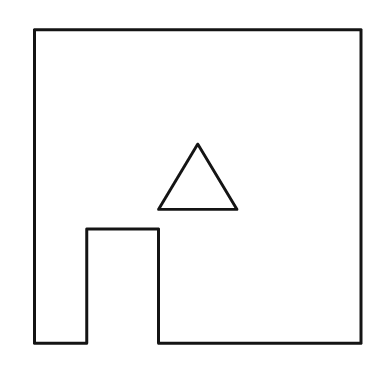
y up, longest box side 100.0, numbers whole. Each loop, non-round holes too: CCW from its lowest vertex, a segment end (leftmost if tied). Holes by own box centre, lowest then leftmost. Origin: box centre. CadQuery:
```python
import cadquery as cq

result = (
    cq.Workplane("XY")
    .moveTo(-50.0, -48.0)
    .lineTo(-34.0, -48.0)
    .lineTo(-34.0, -13.0)
    .lineTo(-12.0, -13.0)
    .lineTo(-12.0, -48.0)
    .lineTo(50.0, -48.0)
    .lineTo(50.0, 48.0)
    .lineTo(-50.0, 48.0)
    .close()
    .moveTo(-12.0, -7.0)
    .lineTo(12.0, -7.0)
    .lineTo(0.0, 13.0)
    .close()
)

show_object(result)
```